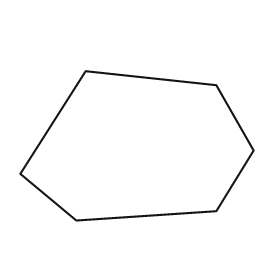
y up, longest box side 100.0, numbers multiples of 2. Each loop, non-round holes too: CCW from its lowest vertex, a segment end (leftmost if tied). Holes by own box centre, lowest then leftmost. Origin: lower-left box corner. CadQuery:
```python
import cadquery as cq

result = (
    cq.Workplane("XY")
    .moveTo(24.0, 0.0)
    .lineTo(84.0, 4.0)
    .lineTo(100.0, 30.0)
    .lineTo(84.0, 58.0)
    .lineTo(28.0, 64.0)
    .lineTo(0.0, 20.0)
    .close()
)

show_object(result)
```